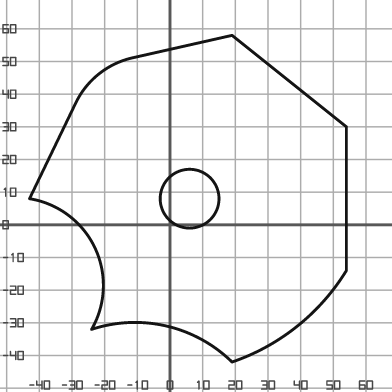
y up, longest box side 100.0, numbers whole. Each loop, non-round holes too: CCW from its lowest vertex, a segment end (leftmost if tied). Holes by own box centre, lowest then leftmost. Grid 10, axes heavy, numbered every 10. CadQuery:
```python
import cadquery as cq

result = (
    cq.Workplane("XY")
    .moveTo(19.0, -42.0)
    .threePointArc((39.0, -31.0), (54.0, -14.0))
    .lineTo(54.0, 30.0)
    .lineTo(19.0, 58.0)
    .lineTo(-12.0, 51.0)
    .threePointArc((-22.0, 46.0), (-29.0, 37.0))
    .lineTo(-43.0, 8.0)
    .threePointArc((-23.0, -7.0), (-24.0, -32.0))
    .threePointArc((-1.0, -31.0), (19.0, -42.0))
    .close()
    .moveTo(6.0, 8.0)
    .circle(9.0)
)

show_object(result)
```